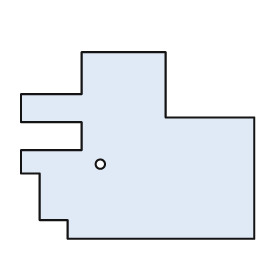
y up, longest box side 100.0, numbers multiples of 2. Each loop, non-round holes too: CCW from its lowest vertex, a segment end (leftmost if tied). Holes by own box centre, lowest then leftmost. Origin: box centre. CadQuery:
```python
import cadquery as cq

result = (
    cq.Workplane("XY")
    .moveTo(-30.0, -40.0)
    .lineTo(50.0, -40.0)
    .lineTo(50.0, 12.0)
    .lineTo(12.0, 12.0)
    .lineTo(12.0, 40.0)
    .lineTo(-24.0, 40.0)
    .lineTo(-24.0, 22.0)
    .lineTo(-50.0, 22.0)
    .lineTo(-50.0, 10.0)
    .lineTo(-24.0, 10.0)
    .lineTo(-24.0, -2.0)
    .lineTo(-50.0, -2.0)
    .lineTo(-50.0, -12.0)
    .lineTo(-42.0, -12.0)
    .lineTo(-42.0, -32.0)
    .lineTo(-30.0, -32.0)
    .close()
    .moveTo(-16.0, -8.0)
    .circle(2.0)
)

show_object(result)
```